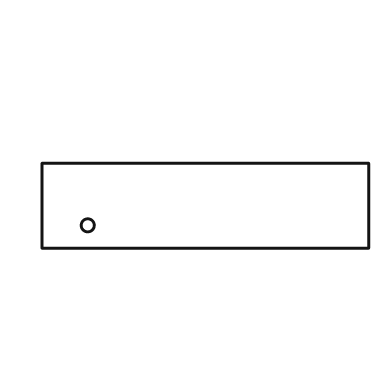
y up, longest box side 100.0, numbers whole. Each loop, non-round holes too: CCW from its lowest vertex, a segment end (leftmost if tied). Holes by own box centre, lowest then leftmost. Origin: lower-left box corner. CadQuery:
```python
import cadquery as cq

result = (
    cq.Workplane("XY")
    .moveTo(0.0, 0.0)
    .lineTo(100.0, 0.0)
    .lineTo(100.0, 26.0)
    .lineTo(0.0, 26.0)
    .close()
    .moveTo(14.0, 7.0)
    .circle(2.0)
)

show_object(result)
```